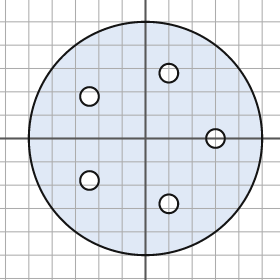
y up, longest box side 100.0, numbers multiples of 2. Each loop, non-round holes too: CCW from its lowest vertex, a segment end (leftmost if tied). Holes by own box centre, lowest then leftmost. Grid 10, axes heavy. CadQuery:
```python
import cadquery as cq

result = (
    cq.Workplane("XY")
    .moveTo(0.0, 0.0)
    .circle(50.0)
    .moveTo(10.0, -28.0)
    .circle(4.0)
    .moveTo(-24.0, -18.0)
    .circle(4.0)
    .moveTo(30.0, 0.0)
    .circle(4.0)
    .moveTo(-24.0, 18.0)
    .circle(4.0)
    .moveTo(10.0, 28.0)
    .circle(4.0)
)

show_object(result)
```